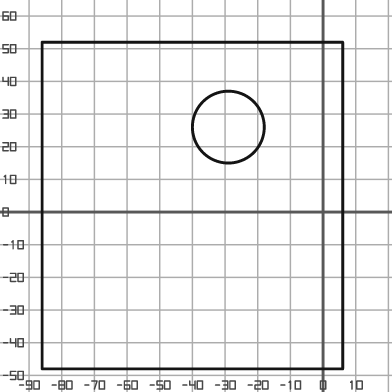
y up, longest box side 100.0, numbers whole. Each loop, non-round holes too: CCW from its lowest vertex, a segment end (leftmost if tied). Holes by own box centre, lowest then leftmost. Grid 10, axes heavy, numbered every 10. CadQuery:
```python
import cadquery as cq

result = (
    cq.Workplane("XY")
    .moveTo(-86.0, -48.0)
    .lineTo(6.0, -48.0)
    .lineTo(6.0, 52.0)
    .lineTo(-86.0, 52.0)
    .close()
    .moveTo(-29.0, 26.0)
    .circle(11.0)
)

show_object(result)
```